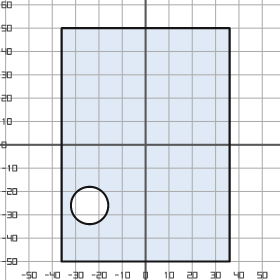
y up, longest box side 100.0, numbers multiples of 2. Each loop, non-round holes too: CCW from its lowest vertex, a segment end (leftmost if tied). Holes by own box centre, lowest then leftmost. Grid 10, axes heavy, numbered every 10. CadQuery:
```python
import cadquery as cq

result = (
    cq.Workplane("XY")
    .moveTo(-36.0, -50.0)
    .lineTo(36.0, -50.0)
    .lineTo(36.0, 50.0)
    .lineTo(-36.0, 50.0)
    .close()
    .moveTo(-24.0, -26.0)
    .circle(8.0)
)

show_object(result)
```